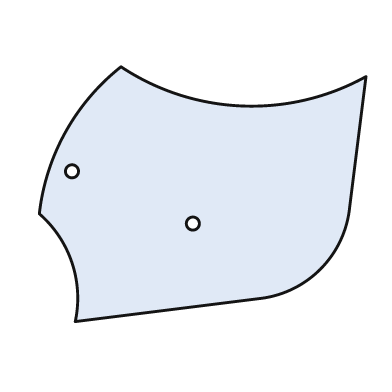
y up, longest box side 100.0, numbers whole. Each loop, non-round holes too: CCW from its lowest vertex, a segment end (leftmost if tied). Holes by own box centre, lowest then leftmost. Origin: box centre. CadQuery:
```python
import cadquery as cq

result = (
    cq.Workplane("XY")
    .moveTo(-39.0, -39.0)
    .lineTo(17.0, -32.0)
    .threePointArc((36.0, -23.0), (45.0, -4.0))
    .lineTo(50.0, 36.0)
    .threePointArc((12.0, 27.0), (-25.0, 39.0))
    .threePointArc((-42.0, 19.0), (-50.0, -6.0))
    .threePointArc((-40.0, -21.0), (-39.0, -39.0))
    .close()
    .moveTo(-3.0, -9.0)
    .circle(2.0)
    .moveTo(-40.0, 7.0)
    .circle(2.0)
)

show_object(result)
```